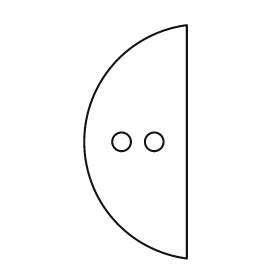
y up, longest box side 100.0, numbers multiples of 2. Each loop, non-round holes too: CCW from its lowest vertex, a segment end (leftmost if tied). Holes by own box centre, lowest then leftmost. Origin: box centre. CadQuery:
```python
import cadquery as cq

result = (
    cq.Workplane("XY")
    .moveTo(22.0, -50.0)
    .lineTo(22.0, 50.0)
    .threePointArc((-22.0, 0.0), (22.0, -50.0))
    .close()
    .moveTo(-6.0, 0.0)
    .circle(4.0)
    .moveTo(8.0, 0.0)
    .circle(4.0)
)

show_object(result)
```